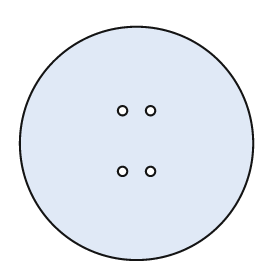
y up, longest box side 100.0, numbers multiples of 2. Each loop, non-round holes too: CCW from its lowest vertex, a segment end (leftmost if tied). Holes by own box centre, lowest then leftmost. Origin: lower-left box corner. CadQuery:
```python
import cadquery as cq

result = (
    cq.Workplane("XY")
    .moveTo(50.0, 50.0)
    .circle(50.0)
    .moveTo(44.0, 38.0)
    .circle(2.0)
    .moveTo(56.0, 38.0)
    .circle(2.0)
    .moveTo(44.0, 64.0)
    .circle(2.0)
    .moveTo(56.0, 64.0)
    .circle(2.0)
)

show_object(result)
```